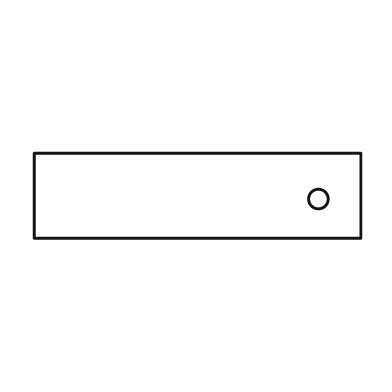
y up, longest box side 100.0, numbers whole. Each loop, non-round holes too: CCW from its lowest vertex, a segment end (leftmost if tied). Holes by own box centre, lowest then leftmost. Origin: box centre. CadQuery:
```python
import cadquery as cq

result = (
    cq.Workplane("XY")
    .moveTo(-50.0, -13.0)
    .lineTo(50.0, -13.0)
    .lineTo(50.0, 13.0)
    .lineTo(-50.0, 13.0)
    .close()
    .moveTo(37.0, -1.0)
    .circle(3.0)
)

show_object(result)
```